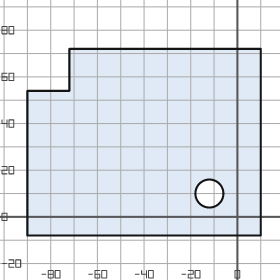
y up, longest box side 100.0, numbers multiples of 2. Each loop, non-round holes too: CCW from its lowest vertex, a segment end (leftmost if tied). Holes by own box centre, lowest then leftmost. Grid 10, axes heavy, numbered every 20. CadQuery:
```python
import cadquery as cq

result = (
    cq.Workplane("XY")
    .moveTo(-90.0, -8.0)
    .lineTo(10.0, -8.0)
    .lineTo(10.0, 72.0)
    .lineTo(-72.0, 72.0)
    .lineTo(-72.0, 54.0)
    .lineTo(-90.0, 54.0)
    .close()
    .moveTo(-12.0, 10.0)
    .circle(6.0)
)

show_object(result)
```